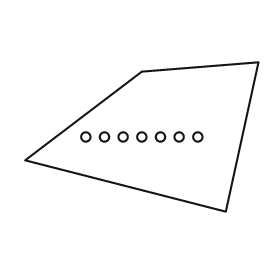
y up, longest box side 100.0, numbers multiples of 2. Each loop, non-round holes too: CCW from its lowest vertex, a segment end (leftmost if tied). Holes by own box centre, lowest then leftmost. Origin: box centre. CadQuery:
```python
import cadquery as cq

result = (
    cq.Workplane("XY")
    .moveTo(36.0, -32.0)
    .lineTo(50.0, 32.0)
    .lineTo(0.0, 28.0)
    .lineTo(-50.0, -10.0)
    .close()
    .moveTo(-24.0, 0.0)
    .circle(2.0)
    .moveTo(-16.0, 0.0)
    .circle(2.0)
    .moveTo(-8.0, 0.0)
    .circle(2.0)
    .moveTo(0.0, 0.0)
    .circle(2.0)
    .moveTo(8.0, 0.0)
    .circle(2.0)
    .moveTo(16.0, 0.0)
    .circle(2.0)
    .moveTo(24.0, 0.0)
    .circle(2.0)
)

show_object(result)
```